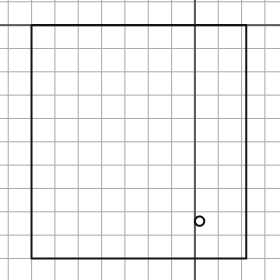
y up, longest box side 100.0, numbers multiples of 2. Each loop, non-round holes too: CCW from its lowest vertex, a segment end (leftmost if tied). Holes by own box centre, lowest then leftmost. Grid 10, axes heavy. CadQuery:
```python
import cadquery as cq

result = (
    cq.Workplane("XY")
    .moveTo(-70.0, -100.0)
    .lineTo(22.0, -100.0)
    .lineTo(22.0, 0.0)
    .lineTo(-70.0, 0.0)
    .close()
    .moveTo(2.0, -84.0)
    .circle(2.0)
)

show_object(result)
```